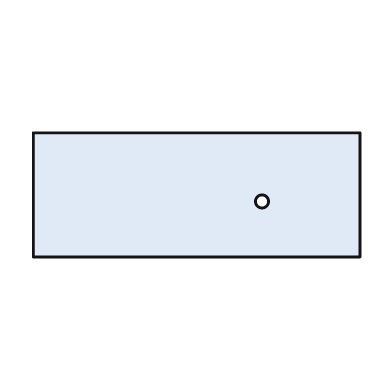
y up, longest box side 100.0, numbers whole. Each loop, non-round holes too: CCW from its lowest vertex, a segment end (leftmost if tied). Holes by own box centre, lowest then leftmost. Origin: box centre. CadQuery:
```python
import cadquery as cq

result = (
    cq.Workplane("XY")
    .moveTo(-50.0, -19.0)
    .lineTo(50.0, -19.0)
    .lineTo(50.0, 19.0)
    .lineTo(-50.0, 19.0)
    .close()
    .moveTo(20.0, -2.0)
    .circle(2.0)
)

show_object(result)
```